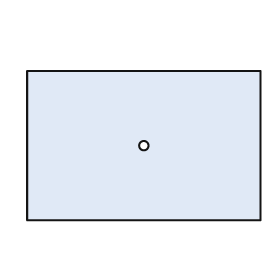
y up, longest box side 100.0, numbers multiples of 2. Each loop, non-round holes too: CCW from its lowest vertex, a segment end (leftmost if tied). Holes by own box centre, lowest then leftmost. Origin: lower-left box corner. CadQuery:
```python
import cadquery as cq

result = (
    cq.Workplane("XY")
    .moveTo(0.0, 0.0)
    .lineTo(100.0, 0.0)
    .lineTo(100.0, 64.0)
    .lineTo(0.0, 64.0)
    .close()
    .moveTo(50.0, 32.0)
    .circle(2.0)
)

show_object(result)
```